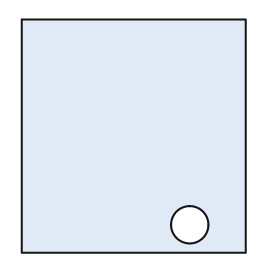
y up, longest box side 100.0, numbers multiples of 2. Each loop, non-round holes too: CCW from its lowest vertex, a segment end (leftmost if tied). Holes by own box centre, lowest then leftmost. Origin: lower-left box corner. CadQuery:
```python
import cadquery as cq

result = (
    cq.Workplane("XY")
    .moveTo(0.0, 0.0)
    .lineTo(96.0, 0.0)
    .lineTo(96.0, 100.0)
    .lineTo(0.0, 100.0)
    .close()
    .moveTo(72.0, 12.0)
    .circle(8.0)
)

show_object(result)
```